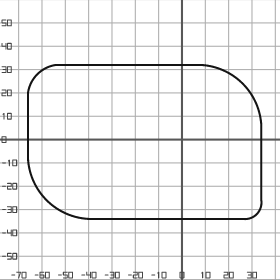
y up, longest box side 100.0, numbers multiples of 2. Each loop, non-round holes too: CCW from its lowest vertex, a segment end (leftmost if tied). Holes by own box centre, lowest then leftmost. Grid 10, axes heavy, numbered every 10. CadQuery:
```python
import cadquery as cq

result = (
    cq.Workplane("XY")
    .moveTo(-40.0, -34.0)
    .lineTo(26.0, -34.0)
    .threePointArc((32.0, -32.0), (34.0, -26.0))
    .lineTo(34.0, 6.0)
    .threePointArc((26.0, 24.0), (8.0, 32.0))
    .lineTo(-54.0, 32.0)
    .threePointArc((-62.0, 28.0), (-66.0, 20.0))
    .lineTo(-66.0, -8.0)
    .threePointArc((-58.0, -26.0), (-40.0, -34.0))
    .close()
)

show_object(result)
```